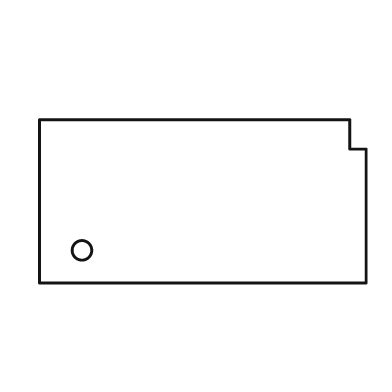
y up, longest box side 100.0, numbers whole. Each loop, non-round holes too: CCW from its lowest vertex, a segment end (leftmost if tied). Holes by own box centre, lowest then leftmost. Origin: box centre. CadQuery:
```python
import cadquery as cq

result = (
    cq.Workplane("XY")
    .moveTo(-50.0, -25.0)
    .lineTo(50.0, -25.0)
    .lineTo(50.0, 16.0)
    .lineTo(45.0, 16.0)
    .lineTo(45.0, 25.0)
    .lineTo(-50.0, 25.0)
    .close()
    .moveTo(-37.0, -15.0)
    .circle(3.0)
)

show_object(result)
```